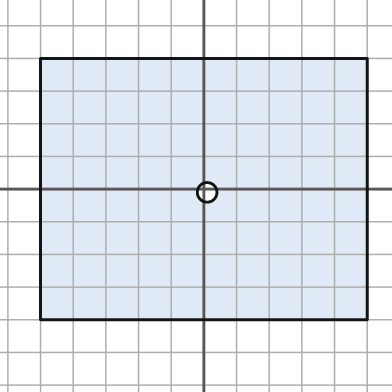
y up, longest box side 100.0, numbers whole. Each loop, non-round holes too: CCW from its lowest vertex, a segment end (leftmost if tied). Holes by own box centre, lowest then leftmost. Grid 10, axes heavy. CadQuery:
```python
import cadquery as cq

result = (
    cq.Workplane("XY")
    .moveTo(-50.0, -40.0)
    .lineTo(50.0, -40.0)
    .lineTo(50.0, 40.0)
    .lineTo(-50.0, 40.0)
    .close()
    .moveTo(1.0, -1.0)
    .circle(3.0)
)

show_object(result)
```